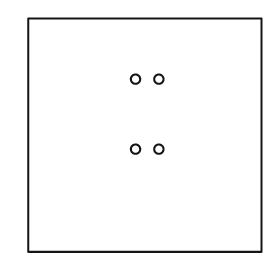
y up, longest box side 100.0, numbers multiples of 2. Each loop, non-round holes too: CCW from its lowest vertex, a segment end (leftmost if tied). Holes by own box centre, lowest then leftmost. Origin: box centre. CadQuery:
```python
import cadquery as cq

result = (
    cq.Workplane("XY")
    .moveTo(-50.0, -50.0)
    .lineTo(50.0, -50.0)
    .lineTo(50.0, 50.0)
    .lineTo(-50.0, 50.0)
    .close()
    .moveTo(-4.0, -6.0)
    .circle(2.0)
    .moveTo(6.0, -6.0)
    .circle(2.0)
    .moveTo(-4.0, 24.0)
    .circle(2.0)
    .moveTo(6.0, 24.0)
    .circle(2.0)
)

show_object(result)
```